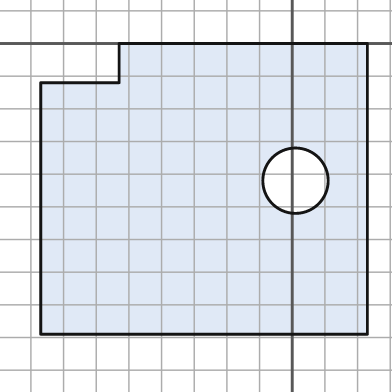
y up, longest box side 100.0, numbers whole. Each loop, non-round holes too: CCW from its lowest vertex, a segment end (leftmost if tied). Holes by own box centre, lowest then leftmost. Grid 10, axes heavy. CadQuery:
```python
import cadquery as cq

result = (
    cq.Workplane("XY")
    .moveTo(-77.0, -89.0)
    .lineTo(23.0, -89.0)
    .lineTo(23.0, 0.0)
    .lineTo(-53.0, 0.0)
    .lineTo(-53.0, -12.0)
    .lineTo(-77.0, -12.0)
    .close()
    .moveTo(1.0, -42.0)
    .circle(10.0)
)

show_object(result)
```